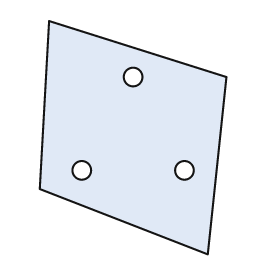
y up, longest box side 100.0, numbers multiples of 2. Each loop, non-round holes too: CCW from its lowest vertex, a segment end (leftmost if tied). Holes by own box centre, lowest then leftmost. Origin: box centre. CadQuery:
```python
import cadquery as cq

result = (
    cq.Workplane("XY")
    .moveTo(32.0, -50.0)
    .lineTo(40.0, 26.0)
    .lineTo(-36.0, 50.0)
    .lineTo(-40.0, -22.0)
    .close()
    .moveTo(-22.0, -14.0)
    .circle(4.0)
    .moveTo(22.0, -14.0)
    .circle(4.0)
    .moveTo(0.0, 26.0)
    .circle(4.0)
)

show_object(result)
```